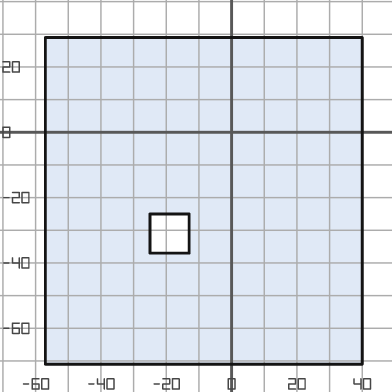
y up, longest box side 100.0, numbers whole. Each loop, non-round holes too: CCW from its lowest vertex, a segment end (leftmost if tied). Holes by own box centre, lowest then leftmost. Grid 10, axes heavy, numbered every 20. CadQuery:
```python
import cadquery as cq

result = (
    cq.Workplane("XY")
    .moveTo(-57.0, -71.0)
    .lineTo(40.0, -71.0)
    .lineTo(40.0, 29.0)
    .lineTo(-57.0, 29.0)
    .close()
    .moveTo(-25.0, -37.0)
    .lineTo(-13.0, -37.0)
    .lineTo(-13.0, -25.0)
    .lineTo(-25.0, -25.0)
    .close()
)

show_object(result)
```